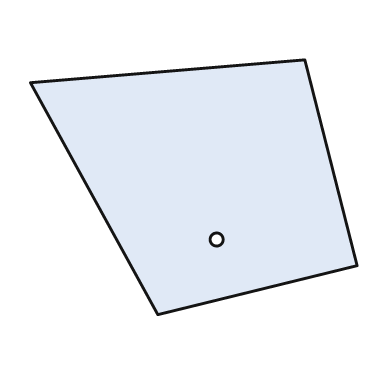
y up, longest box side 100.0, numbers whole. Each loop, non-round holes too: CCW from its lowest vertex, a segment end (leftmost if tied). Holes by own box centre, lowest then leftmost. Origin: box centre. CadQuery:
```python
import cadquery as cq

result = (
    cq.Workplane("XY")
    .moveTo(-11.0, -39.0)
    .lineTo(50.0, -24.0)
    .lineTo(34.0, 39.0)
    .lineTo(-50.0, 32.0)
    .close()
    .moveTo(7.0, -16.0)
    .circle(2.0)
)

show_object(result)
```